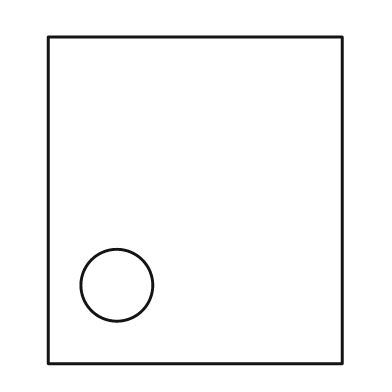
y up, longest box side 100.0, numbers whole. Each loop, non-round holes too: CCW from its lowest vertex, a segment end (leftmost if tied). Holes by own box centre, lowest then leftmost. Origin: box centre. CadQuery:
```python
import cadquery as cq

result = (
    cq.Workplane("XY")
    .moveTo(-45.0, -50.0)
    .lineTo(45.0, -50.0)
    .lineTo(45.0, 50.0)
    .lineTo(-45.0, 50.0)
    .close()
    .moveTo(-24.0, -26.0)
    .circle(11.0)
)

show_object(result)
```